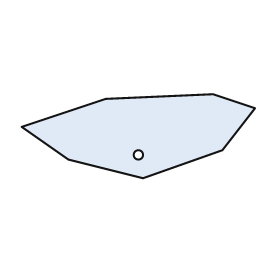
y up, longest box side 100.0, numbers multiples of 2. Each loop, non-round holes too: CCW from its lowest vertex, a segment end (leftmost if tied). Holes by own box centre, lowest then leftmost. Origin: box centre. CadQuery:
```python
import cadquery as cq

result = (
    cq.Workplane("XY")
    .moveTo(2.0, -18.0)
    .lineTo(36.0, -6.0)
    .lineTo(50.0, 12.0)
    .lineTo(32.0, 18.0)
    .lineTo(-14.0, 16.0)
    .lineTo(-50.0, 4.0)
    .lineTo(-30.0, -10.0)
    .close()
    .moveTo(0.0, -8.0)
    .circle(2.0)
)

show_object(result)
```